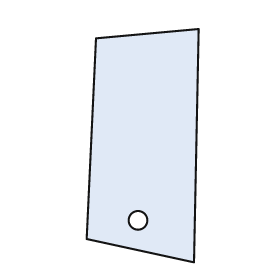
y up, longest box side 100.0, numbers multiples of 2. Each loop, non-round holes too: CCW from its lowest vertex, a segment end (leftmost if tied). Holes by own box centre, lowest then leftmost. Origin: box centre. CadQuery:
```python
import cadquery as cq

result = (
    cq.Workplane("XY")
    .moveTo(22.0, -50.0)
    .lineTo(24.0, 50.0)
    .lineTo(-20.0, 46.0)
    .lineTo(-24.0, -40.0)
    .close()
    .moveTo(-2.0, -32.0)
    .circle(4.0)
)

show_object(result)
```